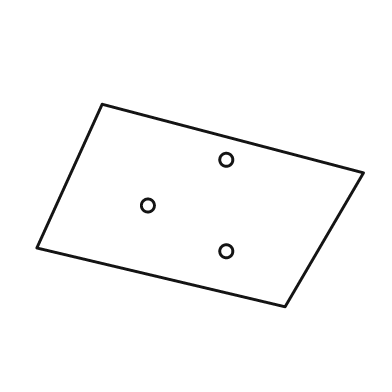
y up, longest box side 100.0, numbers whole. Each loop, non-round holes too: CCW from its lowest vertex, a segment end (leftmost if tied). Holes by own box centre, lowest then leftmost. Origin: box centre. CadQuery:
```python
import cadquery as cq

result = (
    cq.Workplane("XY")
    .moveTo(26.0, -31.0)
    .lineTo(50.0, 10.0)
    .lineTo(-30.0, 31.0)
    .lineTo(-50.0, -13.0)
    .close()
    .moveTo(8.0, -14.0)
    .circle(2.0)
    .moveTo(-16.0, 0.0)
    .circle(2.0)
    .moveTo(8.0, 14.0)
    .circle(2.0)
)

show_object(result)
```